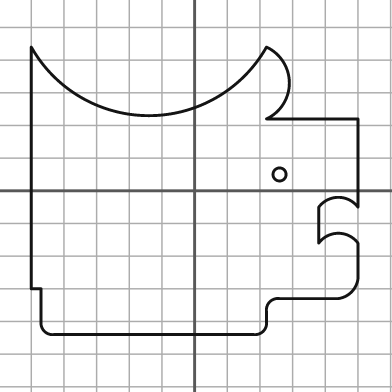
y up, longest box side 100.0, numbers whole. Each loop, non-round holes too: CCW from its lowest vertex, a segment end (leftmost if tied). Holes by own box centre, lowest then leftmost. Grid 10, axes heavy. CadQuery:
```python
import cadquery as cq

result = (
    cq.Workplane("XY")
    .moveTo(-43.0, -44.0)
    .lineTo(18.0, -44.0)
    .threePointArc((21.0, -43.0), (22.0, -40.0))
    .lineTo(22.0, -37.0)
    .threePointArc((23.0, -34.0), (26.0, -33.0))
    .lineTo(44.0, -33.0)
    .threePointArc((48.0, -31.0), (50.0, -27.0))
    .lineTo(50.0, -16.0)
    .threePointArc((44.0, -13.0), (38.0, -16.0))
    .lineTo(38.0, -5.0)
    .threePointArc((44.0, -2.0), (50.0, -5.0))
    .lineTo(50.0, 22.0)
    .lineTo(22.0, 22.0)
    .threePointArc((29.0, 33.0), (22.0, 44.0))
    .threePointArc((-14.0, 23.0), (-50.0, 44.0))
    .lineTo(-50.0, -30.0)
    .lineTo(-47.0, -30.0)
    .lineTo(-47.0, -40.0)
    .threePointArc((-46.0, -43.0), (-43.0, -44.0))
    .close()
    .moveTo(26.0, 5.0)
    .circle(2.0)
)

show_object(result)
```